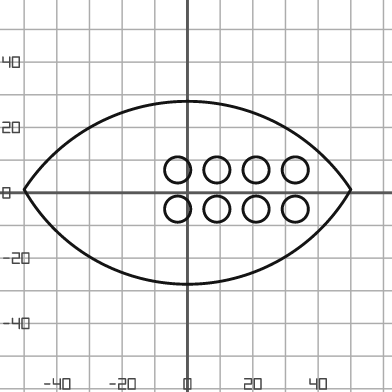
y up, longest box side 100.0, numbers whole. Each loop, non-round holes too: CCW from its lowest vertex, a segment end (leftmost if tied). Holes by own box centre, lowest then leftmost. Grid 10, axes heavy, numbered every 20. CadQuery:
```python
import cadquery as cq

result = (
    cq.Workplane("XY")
    .moveTo(-50.0, 1.0)
    .threePointArc((0.0, -28.0), (50.0, 1.0))
    .threePointArc((0.0, 28.0), (-50.0, 1.0))
    .close()
    .moveTo(-3.0, -5.0)
    .circle(4.0)
    .moveTo(9.0, -5.0)
    .circle(4.0)
    .moveTo(21.0, -5.0)
    .circle(4.0)
    .moveTo(33.0, -5.0)
    .circle(4.0)
    .moveTo(-3.0, 7.0)
    .circle(4.0)
    .moveTo(9.0, 7.0)
    .circle(4.0)
    .moveTo(21.0, 7.0)
    .circle(4.0)
    .moveTo(33.0, 7.0)
    .circle(4.0)
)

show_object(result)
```